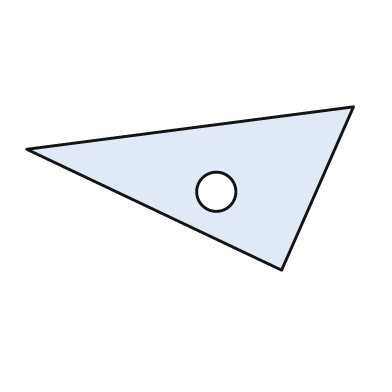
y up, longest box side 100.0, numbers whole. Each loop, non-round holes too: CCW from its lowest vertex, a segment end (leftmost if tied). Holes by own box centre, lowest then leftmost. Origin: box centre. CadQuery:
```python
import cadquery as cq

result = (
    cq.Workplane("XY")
    .moveTo(28.0, -25.0)
    .lineTo(50.0, 25.0)
    .lineTo(-50.0, 12.0)
    .close()
    .moveTo(8.0, -1.0)
    .circle(6.0)
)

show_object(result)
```